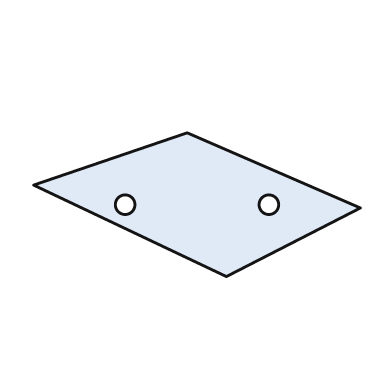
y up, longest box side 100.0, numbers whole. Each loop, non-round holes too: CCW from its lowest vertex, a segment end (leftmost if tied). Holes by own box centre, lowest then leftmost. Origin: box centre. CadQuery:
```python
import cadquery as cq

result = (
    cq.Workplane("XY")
    .moveTo(9.0, -22.0)
    .lineTo(50.0, -1.0)
    .lineTo(-3.0, 22.0)
    .lineTo(-50.0, 6.0)
    .close()
    .moveTo(-22.0, 0.0)
    .circle(3.0)
    .moveTo(22.0, 0.0)
    .circle(3.0)
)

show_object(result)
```